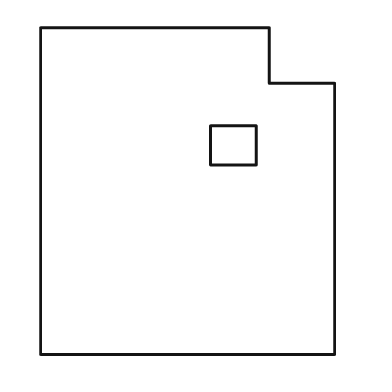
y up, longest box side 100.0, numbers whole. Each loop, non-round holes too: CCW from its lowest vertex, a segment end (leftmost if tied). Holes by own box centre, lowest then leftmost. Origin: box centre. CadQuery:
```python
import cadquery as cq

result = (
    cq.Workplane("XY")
    .moveTo(-45.0, -50.0)
    .lineTo(45.0, -50.0)
    .lineTo(45.0, 33.0)
    .lineTo(25.0, 33.0)
    .lineTo(25.0, 50.0)
    .lineTo(-45.0, 50.0)
    .close()
    .moveTo(7.0, 8.0)
    .lineTo(21.0, 8.0)
    .lineTo(21.0, 20.0)
    .lineTo(7.0, 20.0)
    .close()
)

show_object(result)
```